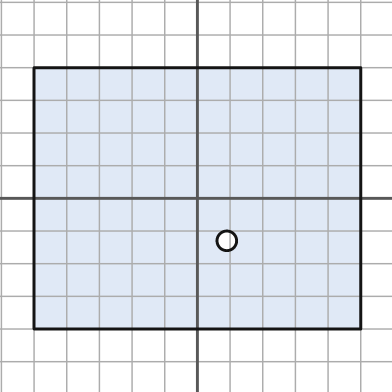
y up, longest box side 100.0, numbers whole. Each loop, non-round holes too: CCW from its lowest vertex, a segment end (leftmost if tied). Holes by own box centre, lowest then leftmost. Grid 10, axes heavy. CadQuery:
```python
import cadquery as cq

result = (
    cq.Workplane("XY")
    .moveTo(-50.0, -40.0)
    .lineTo(50.0, -40.0)
    .lineTo(50.0, 40.0)
    .lineTo(-50.0, 40.0)
    .close()
    .moveTo(9.0, -13.0)
    .circle(3.0)
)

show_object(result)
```